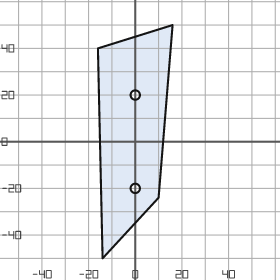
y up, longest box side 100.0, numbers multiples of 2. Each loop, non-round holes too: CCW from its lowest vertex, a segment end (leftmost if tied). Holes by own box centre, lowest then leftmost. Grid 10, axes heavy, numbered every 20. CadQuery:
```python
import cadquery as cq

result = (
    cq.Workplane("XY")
    .moveTo(-14.0, -50.0)
    .lineTo(10.0, -24.0)
    .lineTo(16.0, 50.0)
    .lineTo(-16.0, 40.0)
    .close()
    .moveTo(0.0, -20.0)
    .circle(2.0)
    .moveTo(0.0, 20.0)
    .circle(2.0)
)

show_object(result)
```